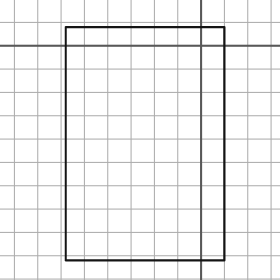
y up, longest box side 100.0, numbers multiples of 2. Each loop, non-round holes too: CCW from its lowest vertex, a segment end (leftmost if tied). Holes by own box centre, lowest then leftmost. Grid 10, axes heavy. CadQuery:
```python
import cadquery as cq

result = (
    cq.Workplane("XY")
    .moveTo(-58.0, -92.0)
    .lineTo(10.0, -92.0)
    .lineTo(10.0, 8.0)
    .lineTo(-58.0, 8.0)
    .close()
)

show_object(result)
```